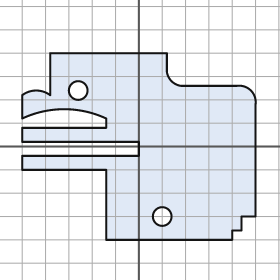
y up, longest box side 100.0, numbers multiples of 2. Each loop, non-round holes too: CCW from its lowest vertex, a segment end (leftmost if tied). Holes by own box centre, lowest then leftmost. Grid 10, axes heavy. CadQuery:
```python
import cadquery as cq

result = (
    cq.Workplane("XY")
    .moveTo(-14.0, -40.0)
    .lineTo(40.0, -40.0)
    .lineTo(40.0, -36.0)
    .lineTo(44.0, -36.0)
    .lineTo(44.0, -30.0)
    .lineTo(50.0, -30.0)
    .lineTo(50.0, 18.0)
    .threePointArc((48.0, 24.0), (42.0, 26.0))
    .lineTo(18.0, 26.0)
    .threePointArc((14.0, 28.0), (12.0, 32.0))
    .lineTo(12.0, 40.0)
    .lineTo(-38.0, 40.0)
    .lineTo(-38.0, 22.0)
    .threePointArc((-44.0, 24.0), (-50.0, 22.0))
    .lineTo(-50.0, 12.0)
    .threePointArc((-32.0, 16.0), (-14.0, 12.0))
    .lineTo(-14.0, 8.0)
    .lineTo(-50.0, 8.0)
    .lineTo(-50.0, 2.0)
    .lineTo(0.0, 2.0)
    .lineTo(0.0, -4.0)
    .lineTo(-50.0, -4.0)
    .lineTo(-50.0, -10.0)
    .lineTo(-14.0, -10.0)
    .close()
    .moveTo(10.0, -30.0)
    .circle(4.0)
    .moveTo(-26.0, 24.0)
    .circle(4.0)
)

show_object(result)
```